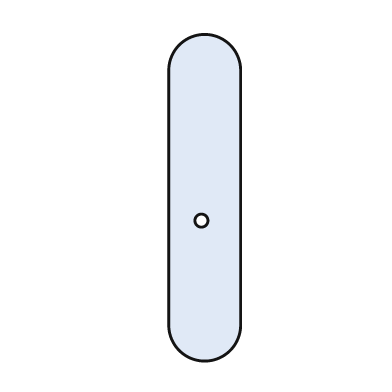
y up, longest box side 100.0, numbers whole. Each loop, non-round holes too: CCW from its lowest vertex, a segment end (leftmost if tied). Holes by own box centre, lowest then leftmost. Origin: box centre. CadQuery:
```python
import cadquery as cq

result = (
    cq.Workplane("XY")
    .moveTo(-11.0, -39.0)
    .threePointArc((0.0, -50.0), (11.0, -39.0))
    .lineTo(11.0, 39.0)
    .threePointArc((0.0, 50.0), (-11.0, 39.0))
    .close()
    .moveTo(-1.0, -7.0)
    .circle(2.0)
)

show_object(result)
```